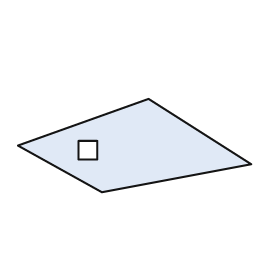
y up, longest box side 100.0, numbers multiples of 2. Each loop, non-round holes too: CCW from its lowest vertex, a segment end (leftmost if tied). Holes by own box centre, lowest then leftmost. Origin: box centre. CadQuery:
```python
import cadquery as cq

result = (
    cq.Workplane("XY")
    .moveTo(-14.0, -20.0)
    .lineTo(50.0, -8.0)
    .lineTo(6.0, 20.0)
    .lineTo(-50.0, 0.0)
    .close()
    .moveTo(-24.0, -6.0)
    .lineTo(-16.0, -6.0)
    .lineTo(-16.0, 2.0)
    .lineTo(-24.0, 2.0)
    .close()
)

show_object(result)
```